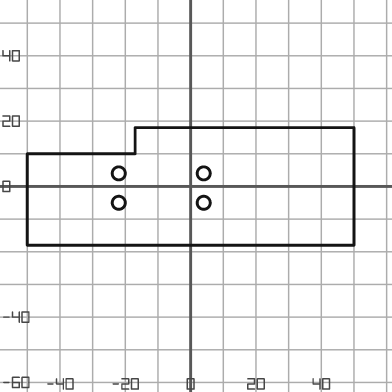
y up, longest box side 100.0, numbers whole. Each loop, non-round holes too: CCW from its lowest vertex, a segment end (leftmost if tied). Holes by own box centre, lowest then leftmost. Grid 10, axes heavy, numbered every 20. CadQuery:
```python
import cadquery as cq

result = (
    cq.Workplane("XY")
    .moveTo(-50.0, -18.0)
    .lineTo(50.0, -18.0)
    .lineTo(50.0, 18.0)
    .lineTo(-17.0, 18.0)
    .lineTo(-17.0, 10.0)
    .lineTo(-50.0, 10.0)
    .close()
    .moveTo(-22.0, -5.0)
    .circle(2.0)
    .moveTo(4.0, -5.0)
    .circle(2.0)
    .moveTo(-22.0, 4.0)
    .circle(2.0)
    .moveTo(4.0, 4.0)
    .circle(2.0)
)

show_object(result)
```